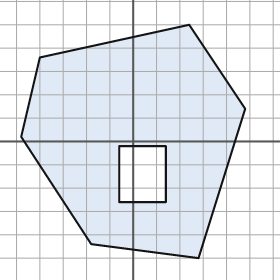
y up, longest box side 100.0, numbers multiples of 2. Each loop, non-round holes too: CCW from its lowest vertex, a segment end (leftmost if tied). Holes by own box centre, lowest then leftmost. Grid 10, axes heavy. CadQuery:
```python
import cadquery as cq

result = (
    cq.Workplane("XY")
    .moveTo(28.0, -50.0)
    .lineTo(48.0, 14.0)
    .lineTo(24.0, 50.0)
    .lineTo(-40.0, 36.0)
    .lineTo(-48.0, 2.0)
    .lineTo(-18.0, -44.0)
    .close()
    .moveTo(-6.0, -26.0)
    .lineTo(14.0, -26.0)
    .lineTo(14.0, -2.0)
    .lineTo(-6.0, -2.0)
    .close()
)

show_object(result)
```